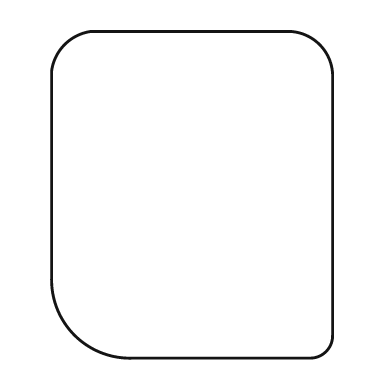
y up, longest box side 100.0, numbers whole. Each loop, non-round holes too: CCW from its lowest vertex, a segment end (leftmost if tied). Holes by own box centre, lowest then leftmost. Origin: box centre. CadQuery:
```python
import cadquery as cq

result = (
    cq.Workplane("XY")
    .moveTo(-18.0, -50.0)
    .lineTo(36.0, -50.0)
    .threePointArc((41.0, -48.0), (43.0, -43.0))
    .lineTo(43.0, 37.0)
    .threePointArc((39.0, 46.0), (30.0, 50.0))
    .lineTo(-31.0, 50.0)
    .threePointArc((-39.0, 46.0), (-43.0, 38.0))
    .lineTo(-43.0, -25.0)
    .threePointArc((-36.0, -43.0), (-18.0, -50.0))
    .close()
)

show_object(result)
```